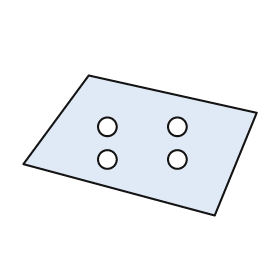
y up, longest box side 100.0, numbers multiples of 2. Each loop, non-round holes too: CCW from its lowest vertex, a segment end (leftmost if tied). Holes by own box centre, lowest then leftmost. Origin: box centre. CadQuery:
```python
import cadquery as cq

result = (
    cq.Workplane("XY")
    .moveTo(32.0, -30.0)
    .lineTo(50.0, 14.0)
    .lineTo(-22.0, 30.0)
    .lineTo(-50.0, -8.0)
    .close()
    .moveTo(-14.0, -6.0)
    .circle(4.0)
    .moveTo(16.0, -6.0)
    .circle(4.0)
    .moveTo(-14.0, 8.0)
    .circle(4.0)
    .moveTo(16.0, 8.0)
    .circle(4.0)
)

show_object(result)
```